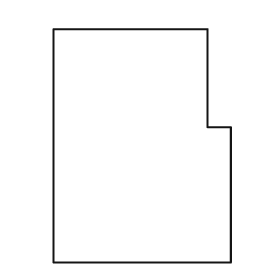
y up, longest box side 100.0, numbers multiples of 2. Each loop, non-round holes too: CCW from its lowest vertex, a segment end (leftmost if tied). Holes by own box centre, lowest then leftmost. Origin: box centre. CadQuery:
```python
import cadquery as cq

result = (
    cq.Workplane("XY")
    .moveTo(-38.0, -50.0)
    .lineTo(38.0, -50.0)
    .lineTo(38.0, 8.0)
    .lineTo(28.0, 8.0)
    .lineTo(28.0, 50.0)
    .lineTo(-38.0, 50.0)
    .close()
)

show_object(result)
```